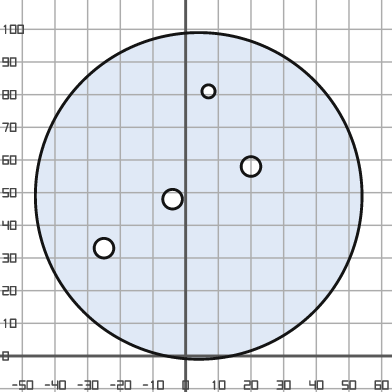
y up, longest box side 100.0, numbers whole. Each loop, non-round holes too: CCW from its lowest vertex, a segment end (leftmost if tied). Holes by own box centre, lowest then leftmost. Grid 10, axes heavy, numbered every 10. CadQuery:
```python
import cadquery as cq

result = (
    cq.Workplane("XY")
    .moveTo(4.0, 49.0)
    .circle(50.0)
    .moveTo(-25.0, 33.0)
    .circle(3.0)
    .moveTo(-4.0, 48.0)
    .circle(3.0)
    .moveTo(20.0, 58.0)
    .circle(3.0)
    .moveTo(7.0, 81.0)
    .circle(2.0)
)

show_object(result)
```